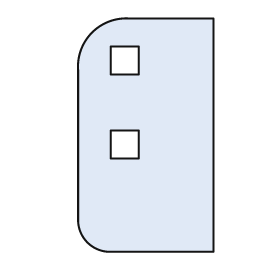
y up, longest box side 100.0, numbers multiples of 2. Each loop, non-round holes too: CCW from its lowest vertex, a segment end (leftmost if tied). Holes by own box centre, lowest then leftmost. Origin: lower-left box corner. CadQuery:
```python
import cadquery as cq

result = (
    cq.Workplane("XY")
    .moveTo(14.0, 0.0)
    .lineTo(58.0, 0.0)
    .lineTo(58.0, 100.0)
    .lineTo(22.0, 100.0)
    .threePointArc((6.0, 94.0), (0.0, 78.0))
    .lineTo(0.0, 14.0)
    .threePointArc((4.0, 4.0), (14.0, 0.0))
    .close()
    .moveTo(14.0, 40.0)
    .lineTo(26.0, 40.0)
    .lineTo(26.0, 52.0)
    .lineTo(14.0, 52.0)
    .close()
    .moveTo(14.0, 76.0)
    .lineTo(26.0, 76.0)
    .lineTo(26.0, 88.0)
    .lineTo(14.0, 88.0)
    .close()
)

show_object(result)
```